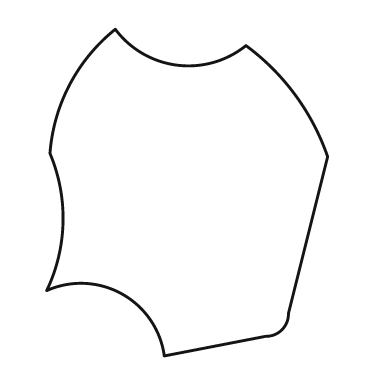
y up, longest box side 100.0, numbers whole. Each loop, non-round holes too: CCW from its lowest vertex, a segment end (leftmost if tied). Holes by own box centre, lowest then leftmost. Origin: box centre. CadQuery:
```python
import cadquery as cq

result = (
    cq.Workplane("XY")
    .moveTo(-7.0, -50.0)
    .lineTo(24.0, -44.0)
    .threePointArc((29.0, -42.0), (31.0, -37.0))
    .lineTo(43.0, 11.0)
    .threePointArc((33.0, 30.0), (18.0, 45.0))
    .threePointArc((-3.0, 39.0), (-22.0, 50.0))
    .threePointArc((-36.0, 33.0), (-42.0, 12.0))
    .threePointArc((-38.0, -9.0), (-43.0, -30.0))
    .threePointArc((-20.0, -31.0), (-7.0, -50.0))
    .close()
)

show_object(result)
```